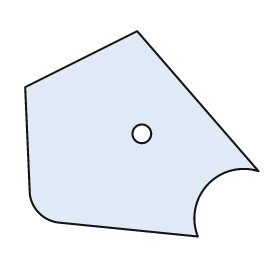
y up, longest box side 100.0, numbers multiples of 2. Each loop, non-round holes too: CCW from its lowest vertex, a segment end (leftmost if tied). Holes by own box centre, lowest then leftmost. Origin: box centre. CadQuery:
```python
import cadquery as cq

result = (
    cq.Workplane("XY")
    .moveTo(24.0, -44.0)
    .threePointArc((28.0, -22.0), (50.0, -16.0))
    .lineTo(-2.0, 44.0)
    .lineTo(-50.0, 20.0)
    .lineTo(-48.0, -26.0)
    .threePointArc((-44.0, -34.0), (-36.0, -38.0))
    .close()
    .moveTo(0.0, 0.0)
    .circle(4.0)
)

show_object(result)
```